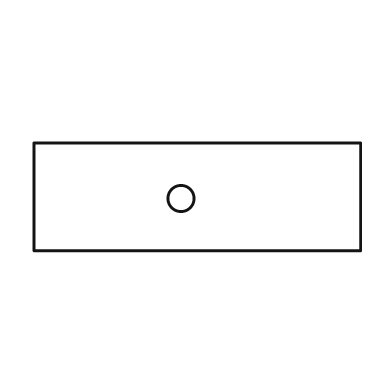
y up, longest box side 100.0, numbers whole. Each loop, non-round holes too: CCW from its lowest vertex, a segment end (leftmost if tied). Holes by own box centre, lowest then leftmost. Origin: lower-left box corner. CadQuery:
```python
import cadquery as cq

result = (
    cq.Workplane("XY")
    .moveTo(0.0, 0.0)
    .lineTo(100.0, 0.0)
    .lineTo(100.0, 33.0)
    .lineTo(0.0, 33.0)
    .close()
    .moveTo(45.0, 16.0)
    .circle(4.0)
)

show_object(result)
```